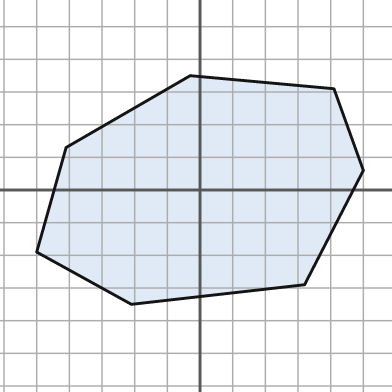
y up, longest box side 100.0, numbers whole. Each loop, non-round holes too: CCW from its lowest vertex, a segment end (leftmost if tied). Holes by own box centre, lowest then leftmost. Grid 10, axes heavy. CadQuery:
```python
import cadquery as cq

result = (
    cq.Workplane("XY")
    .moveTo(-21.0, -35.0)
    .lineTo(32.0, -29.0)
    .lineTo(50.0, 6.0)
    .lineTo(41.0, 31.0)
    .lineTo(-3.0, 35.0)
    .lineTo(-41.0, 13.0)
    .lineTo(-50.0, -19.0)
    .close()
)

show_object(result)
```